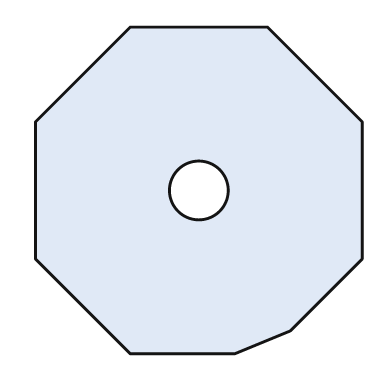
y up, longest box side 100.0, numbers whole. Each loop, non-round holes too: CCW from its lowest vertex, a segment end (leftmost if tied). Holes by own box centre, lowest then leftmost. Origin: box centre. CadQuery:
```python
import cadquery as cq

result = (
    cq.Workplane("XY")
    .moveTo(-21.0, -50.0)
    .lineTo(11.0, -50.0)
    .lineTo(28.0, -43.0)
    .lineTo(50.0, -21.0)
    .lineTo(50.0, 21.0)
    .lineTo(21.0, 50.0)
    .lineTo(-21.0, 50.0)
    .lineTo(-50.0, 21.0)
    .lineTo(-50.0, -21.0)
    .close()
    .moveTo(0.0, 0.0)
    .circle(9.0)
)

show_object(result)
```